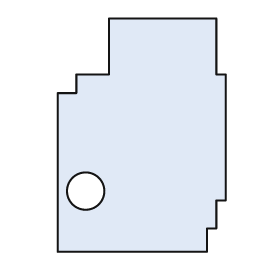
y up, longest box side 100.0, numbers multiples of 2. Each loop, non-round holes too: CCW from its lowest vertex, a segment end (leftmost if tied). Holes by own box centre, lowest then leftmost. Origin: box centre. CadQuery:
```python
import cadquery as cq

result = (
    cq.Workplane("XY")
    .moveTo(-36.0, -50.0)
    .lineTo(28.0, -50.0)
    .lineTo(28.0, -40.0)
    .lineTo(32.0, -40.0)
    .lineTo(32.0, -28.0)
    .lineTo(36.0, -28.0)
    .lineTo(36.0, 26.0)
    .lineTo(32.0, 26.0)
    .lineTo(32.0, 50.0)
    .lineTo(-14.0, 50.0)
    .lineTo(-14.0, 26.0)
    .lineTo(-28.0, 26.0)
    .lineTo(-28.0, 18.0)
    .lineTo(-36.0, 18.0)
    .close()
    .moveTo(-24.0, -24.0)
    .circle(8.0)
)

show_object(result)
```